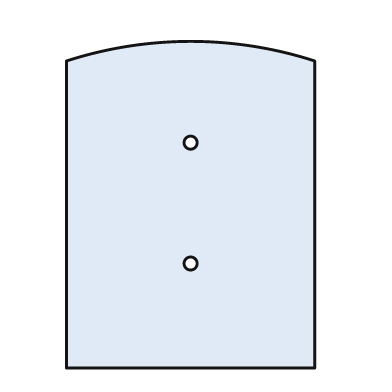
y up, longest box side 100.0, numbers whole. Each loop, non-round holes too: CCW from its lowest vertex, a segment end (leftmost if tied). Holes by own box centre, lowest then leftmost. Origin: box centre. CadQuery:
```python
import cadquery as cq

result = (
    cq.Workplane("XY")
    .moveTo(-38.0, -50.0)
    .lineTo(38.0, -50.0)
    .lineTo(38.0, 44.0)
    .threePointArc((0.0, 50.0), (-38.0, 44.0))
    .close()
    .moveTo(0.0, -18.0)
    .circle(2.0)
    .moveTo(0.0, 19.0)
    .circle(2.0)
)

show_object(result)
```